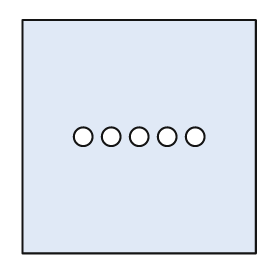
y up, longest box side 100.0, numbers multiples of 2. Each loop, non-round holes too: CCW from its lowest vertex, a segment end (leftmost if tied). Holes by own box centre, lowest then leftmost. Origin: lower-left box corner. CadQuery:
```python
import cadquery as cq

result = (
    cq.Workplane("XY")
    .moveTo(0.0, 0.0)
    .lineTo(100.0, 0.0)
    .lineTo(100.0, 100.0)
    .lineTo(0.0, 100.0)
    .close()
    .moveTo(26.0, 50.0)
    .circle(4.0)
    .moveTo(38.0, 50.0)
    .circle(4.0)
    .moveTo(50.0, 50.0)
    .circle(4.0)
    .moveTo(62.0, 50.0)
    .circle(4.0)
    .moveTo(74.0, 50.0)
    .circle(4.0)
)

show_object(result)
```